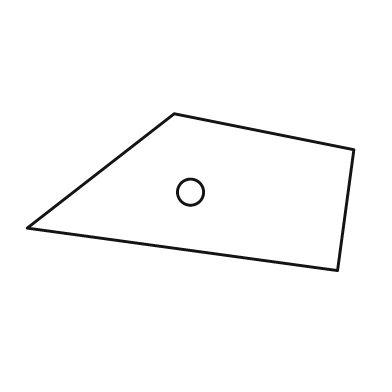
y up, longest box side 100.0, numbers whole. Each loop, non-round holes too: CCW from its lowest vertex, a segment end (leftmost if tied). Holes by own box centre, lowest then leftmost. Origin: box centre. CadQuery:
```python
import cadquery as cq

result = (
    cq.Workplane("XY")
    .moveTo(45.0, -24.0)
    .lineTo(50.0, 13.0)
    .lineTo(-5.0, 24.0)
    .lineTo(-50.0, -11.0)
    .close()
    .moveTo(0.0, 0.0)
    .circle(4.0)
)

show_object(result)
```